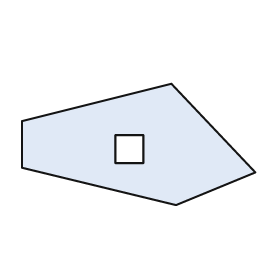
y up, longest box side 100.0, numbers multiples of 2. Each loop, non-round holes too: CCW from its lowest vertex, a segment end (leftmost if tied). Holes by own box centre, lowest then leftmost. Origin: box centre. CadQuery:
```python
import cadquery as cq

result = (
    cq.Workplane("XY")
    .moveTo(16.0, -26.0)
    .lineTo(50.0, -12.0)
    .lineTo(14.0, 26.0)
    .lineTo(-50.0, 10.0)
    .lineTo(-50.0, -10.0)
    .close()
    .moveTo(-10.0, -8.0)
    .lineTo(2.0, -8.0)
    .lineTo(2.0, 4.0)
    .lineTo(-10.0, 4.0)
    .close()
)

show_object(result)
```